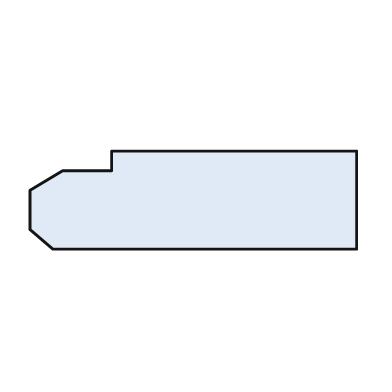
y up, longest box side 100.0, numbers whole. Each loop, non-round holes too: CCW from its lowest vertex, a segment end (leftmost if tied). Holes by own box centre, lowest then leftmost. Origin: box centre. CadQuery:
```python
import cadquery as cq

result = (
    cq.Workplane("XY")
    .moveTo(-43.0, -15.0)
    .lineTo(50.0, -15.0)
    .lineTo(50.0, 15.0)
    .lineTo(-25.0, 15.0)
    .lineTo(-25.0, 9.0)
    .lineTo(-40.0, 9.0)
    .lineTo(-50.0, 3.0)
    .lineTo(-50.0, -9.0)
    .close()
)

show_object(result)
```